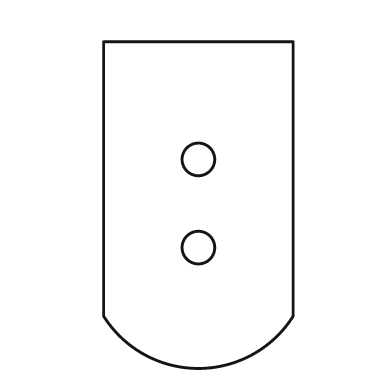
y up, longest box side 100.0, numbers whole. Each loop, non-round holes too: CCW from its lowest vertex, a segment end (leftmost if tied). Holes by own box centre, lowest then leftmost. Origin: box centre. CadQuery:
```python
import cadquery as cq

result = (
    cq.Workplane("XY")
    .moveTo(-29.0, -34.0)
    .threePointArc((0.0, -50.0), (29.0, -34.0))
    .lineTo(29.0, 50.0)
    .lineTo(-29.0, 50.0)
    .close()
    .moveTo(0.0, -13.0)
    .circle(5.0)
    .moveTo(0.0, 14.0)
    .circle(5.0)
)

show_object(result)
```